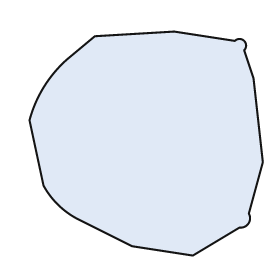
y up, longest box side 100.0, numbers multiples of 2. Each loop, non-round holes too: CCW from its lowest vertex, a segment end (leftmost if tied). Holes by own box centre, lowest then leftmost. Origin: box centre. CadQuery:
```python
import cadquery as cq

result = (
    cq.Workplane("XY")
    .moveTo(20.0, -48.0)
    .lineTo(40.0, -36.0)
    .threePointArc((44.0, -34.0), (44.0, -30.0))
    .lineTo(50.0, -8.0)
    .lineTo(46.0, 28.0)
    .lineTo(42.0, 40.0)
    .threePointArc((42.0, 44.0), (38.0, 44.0))
    .lineTo(12.0, 48.0)
    .lineTo(-22.0, 46.0)
    .lineTo(-34.0, 36.0)
    .threePointArc((-44.0, 24.0), (-50.0, 10.0))
    .lineTo(-44.0, -18.0)
    .threePointArc((-38.0, -26.0), (-30.0, -32.0))
    .lineTo(-6.0, -44.0)
    .close()
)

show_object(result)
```